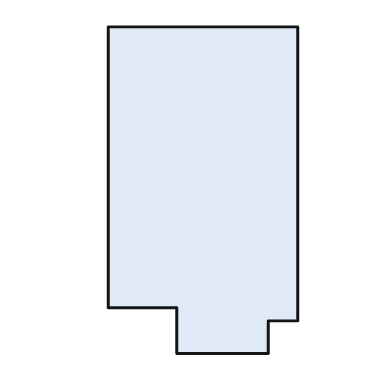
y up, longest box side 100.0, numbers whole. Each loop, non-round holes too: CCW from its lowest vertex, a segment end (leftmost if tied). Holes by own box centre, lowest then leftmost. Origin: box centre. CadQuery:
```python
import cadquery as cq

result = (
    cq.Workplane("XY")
    .moveTo(-8.0, -50.0)
    .lineTo(20.0, -50.0)
    .lineTo(20.0, -40.0)
    .lineTo(29.0, -40.0)
    .lineTo(29.0, 50.0)
    .lineTo(-29.0, 50.0)
    .lineTo(-29.0, -36.0)
    .lineTo(-8.0, -36.0)
    .close()
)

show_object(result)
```